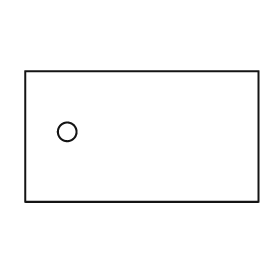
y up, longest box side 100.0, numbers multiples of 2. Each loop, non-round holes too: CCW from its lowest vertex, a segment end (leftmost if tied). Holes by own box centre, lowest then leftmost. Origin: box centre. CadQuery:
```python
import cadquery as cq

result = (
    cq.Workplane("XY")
    .moveTo(-50.0, -28.0)
    .lineTo(50.0, -28.0)
    .lineTo(50.0, 28.0)
    .lineTo(-50.0, 28.0)
    .close()
    .moveTo(-32.0, 2.0)
    .circle(4.0)
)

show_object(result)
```